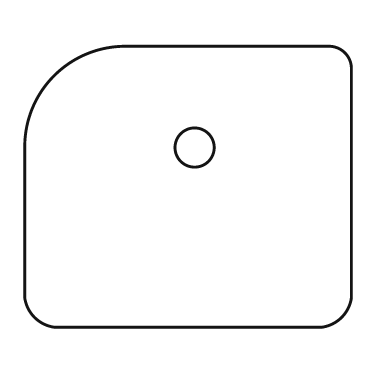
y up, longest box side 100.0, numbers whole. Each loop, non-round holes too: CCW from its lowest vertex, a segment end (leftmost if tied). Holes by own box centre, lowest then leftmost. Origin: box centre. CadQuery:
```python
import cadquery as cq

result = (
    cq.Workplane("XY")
    .moveTo(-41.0, -43.0)
    .lineTo(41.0, -43.0)
    .threePointArc((47.0, -40.0), (50.0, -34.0))
    .lineTo(50.0, 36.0)
    .threePointArc((48.0, 41.0), (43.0, 43.0))
    .lineTo(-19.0, 43.0)
    .threePointArc((-41.0, 34.0), (-50.0, 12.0))
    .lineTo(-50.0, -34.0)
    .threePointArc((-47.0, -40.0), (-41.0, -43.0))
    .close()
    .moveTo(2.0, 12.0)
    .circle(6.0)
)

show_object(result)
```